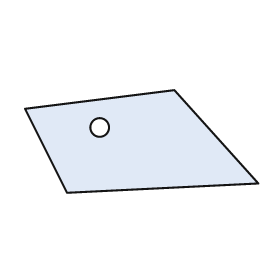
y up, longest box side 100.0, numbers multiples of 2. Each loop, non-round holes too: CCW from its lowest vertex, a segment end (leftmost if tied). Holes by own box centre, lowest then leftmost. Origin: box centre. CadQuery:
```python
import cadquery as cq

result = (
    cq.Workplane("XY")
    .moveTo(-32.0, -22.0)
    .lineTo(50.0, -18.0)
    .lineTo(14.0, 22.0)
    .lineTo(-50.0, 14.0)
    .close()
    .moveTo(-18.0, 6.0)
    .circle(4.0)
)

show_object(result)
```